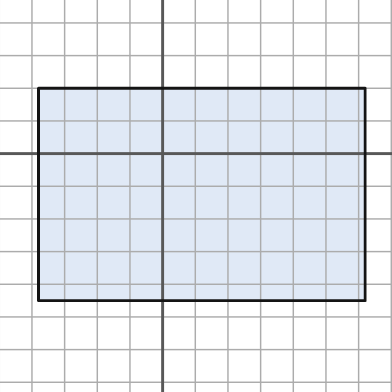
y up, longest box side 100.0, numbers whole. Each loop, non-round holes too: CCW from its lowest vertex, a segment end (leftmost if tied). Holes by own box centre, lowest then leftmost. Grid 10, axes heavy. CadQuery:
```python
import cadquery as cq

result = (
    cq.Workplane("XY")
    .moveTo(-38.0, -45.0)
    .lineTo(62.0, -45.0)
    .lineTo(62.0, 20.0)
    .lineTo(-38.0, 20.0)
    .close()
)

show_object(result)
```